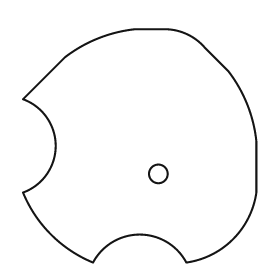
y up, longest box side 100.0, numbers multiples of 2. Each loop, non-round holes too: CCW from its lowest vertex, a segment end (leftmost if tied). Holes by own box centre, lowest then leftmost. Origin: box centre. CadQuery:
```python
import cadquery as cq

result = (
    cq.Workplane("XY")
    .moveTo(-20.0, -50.0)
    .threePointArc((0.0, -38.0), (20.0, -50.0))
    .threePointArc((40.0, -40.0), (50.0, -20.0))
    .lineTo(50.0, 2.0)
    .threePointArc((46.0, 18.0), (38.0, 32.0))
    .lineTo(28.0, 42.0)
    .threePointArc((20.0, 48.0), (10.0, 50.0))
    .lineTo(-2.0, 50.0)
    .threePointArc((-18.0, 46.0), (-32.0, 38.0))
    .lineTo(-50.0, 20.0)
    .threePointArc((-36.0, 0.0), (-50.0, -20.0))
    .threePointArc((-38.0, -38.0), (-20.0, -50.0))
    .close()
    .moveTo(8.0, -12.0)
    .circle(4.0)
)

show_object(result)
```